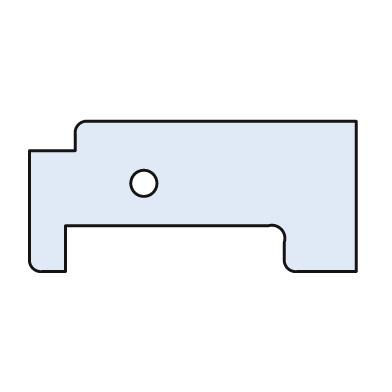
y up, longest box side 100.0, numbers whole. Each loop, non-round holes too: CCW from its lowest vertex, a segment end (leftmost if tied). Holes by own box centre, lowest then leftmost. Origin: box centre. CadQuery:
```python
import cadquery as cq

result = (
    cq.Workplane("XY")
    .moveTo(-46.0, -23.0)
    .lineTo(-39.0, -23.0)
    .lineTo(-39.0, -9.0)
    .lineTo(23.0, -9.0)
    .threePointArc((27.0, -10.0), (28.0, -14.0))
    .lineTo(28.0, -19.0)
    .threePointArc((29.0, -22.0), (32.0, -23.0))
    .lineTo(50.0, -23.0)
    .lineTo(50.0, 23.0)
    .lineTo(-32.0, 23.0)
    .threePointArc((-35.0, 22.0), (-36.0, 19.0))
    .lineTo(-36.0, 14.0)
    .lineTo(-50.0, 14.0)
    .lineTo(-50.0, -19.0)
    .threePointArc((-49.0, -22.0), (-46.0, -23.0))
    .close()
    .moveTo(-15.0, 4.0)
    .circle(4.0)
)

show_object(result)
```